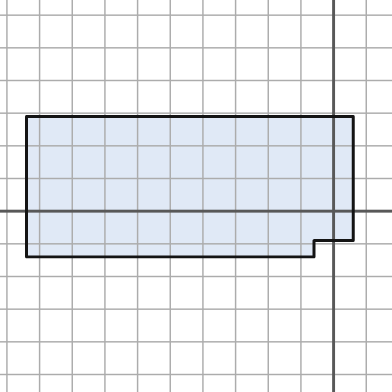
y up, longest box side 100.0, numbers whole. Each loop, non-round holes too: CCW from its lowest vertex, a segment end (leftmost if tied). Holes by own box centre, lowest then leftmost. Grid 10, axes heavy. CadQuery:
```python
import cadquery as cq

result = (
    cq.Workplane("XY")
    .moveTo(-94.0, -14.0)
    .lineTo(-6.0, -14.0)
    .lineTo(-6.0, -9.0)
    .lineTo(6.0, -9.0)
    .lineTo(6.0, 29.0)
    .lineTo(-94.0, 29.0)
    .close()
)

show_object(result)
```